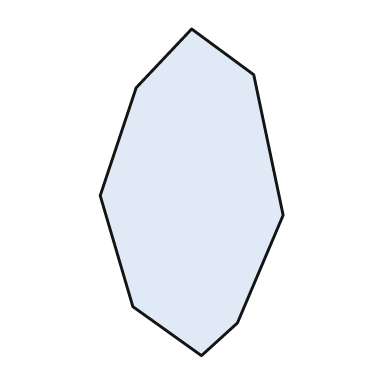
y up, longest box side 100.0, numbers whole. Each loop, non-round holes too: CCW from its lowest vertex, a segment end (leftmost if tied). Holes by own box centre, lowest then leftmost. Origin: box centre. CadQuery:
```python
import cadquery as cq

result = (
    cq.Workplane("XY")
    .moveTo(3.0, -50.0)
    .lineTo(14.0, -40.0)
    .lineTo(28.0, -7.0)
    .lineTo(19.0, 36.0)
    .lineTo(0.0, 50.0)
    .lineTo(-17.0, 32.0)
    .lineTo(-28.0, -1.0)
    .lineTo(-18.0, -35.0)
    .close()
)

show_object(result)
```